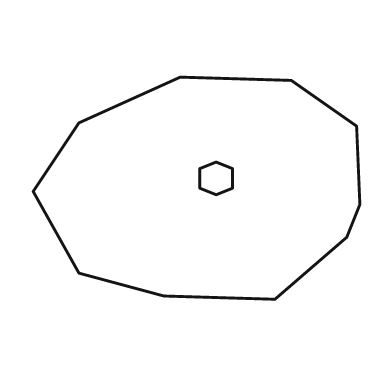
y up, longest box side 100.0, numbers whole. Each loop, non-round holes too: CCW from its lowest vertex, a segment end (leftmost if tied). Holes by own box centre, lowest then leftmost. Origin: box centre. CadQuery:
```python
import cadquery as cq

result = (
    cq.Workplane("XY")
    .moveTo(24.0, -34.0)
    .lineTo(46.0, -15.0)
    .lineTo(50.0, -5.0)
    .lineTo(49.0, 19.0)
    .lineTo(29.0, 33.0)
    .lineTo(-5.0, 34.0)
    .lineTo(-36.0, 20.0)
    .lineTo(-50.0, -1.0)
    .lineTo(-36.0, -26.0)
    .lineTo(-10.0, -33.0)
    .close()
    .moveTo(6.0, -2.0)
    .lineTo(11.0, 0.0)
    .lineTo(11.0, 6.0)
    .lineTo(6.0, 8.0)
    .lineTo(1.0, 6.0)
    .lineTo(1.0, 0.0)
    .close()
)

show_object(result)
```